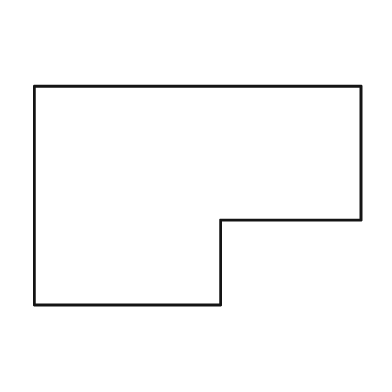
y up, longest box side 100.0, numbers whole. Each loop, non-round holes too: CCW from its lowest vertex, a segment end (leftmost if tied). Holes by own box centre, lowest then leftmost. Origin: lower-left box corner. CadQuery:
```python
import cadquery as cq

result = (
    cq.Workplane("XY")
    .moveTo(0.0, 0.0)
    .lineTo(57.0, 0.0)
    .lineTo(57.0, 26.0)
    .lineTo(100.0, 26.0)
    .lineTo(100.0, 67.0)
    .lineTo(0.0, 67.0)
    .close()
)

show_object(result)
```